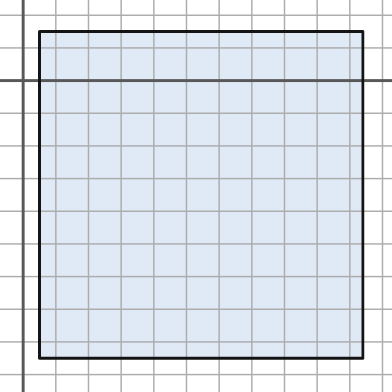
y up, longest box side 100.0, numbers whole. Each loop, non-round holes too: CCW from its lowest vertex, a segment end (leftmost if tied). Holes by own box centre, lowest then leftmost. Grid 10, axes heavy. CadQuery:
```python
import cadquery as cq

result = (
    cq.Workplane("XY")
    .moveTo(5.0, -85.0)
    .lineTo(104.0, -85.0)
    .lineTo(104.0, 15.0)
    .lineTo(5.0, 15.0)
    .close()
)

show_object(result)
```